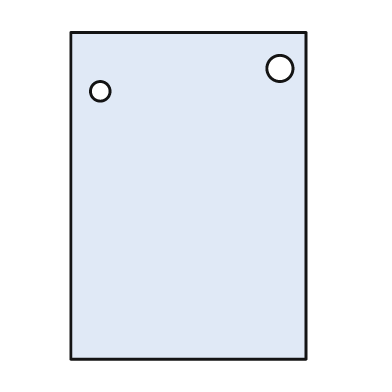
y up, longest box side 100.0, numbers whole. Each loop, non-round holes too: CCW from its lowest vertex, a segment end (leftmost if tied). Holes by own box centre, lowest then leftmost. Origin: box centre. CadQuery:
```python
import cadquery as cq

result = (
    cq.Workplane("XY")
    .moveTo(-36.0, -50.0)
    .lineTo(36.0, -50.0)
    .lineTo(36.0, 50.0)
    .lineTo(-36.0, 50.0)
    .close()
    .moveTo(-27.0, 32.0)
    .circle(3.0)
    .moveTo(28.0, 39.0)
    .circle(4.0)
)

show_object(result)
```